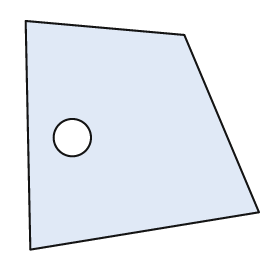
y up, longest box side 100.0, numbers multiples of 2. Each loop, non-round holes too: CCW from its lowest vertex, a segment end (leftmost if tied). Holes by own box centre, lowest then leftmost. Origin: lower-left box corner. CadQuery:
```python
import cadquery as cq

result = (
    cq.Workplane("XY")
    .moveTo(2.0, 0.0)
    .lineTo(100.0, 16.0)
    .lineTo(68.0, 92.0)
    .lineTo(0.0, 98.0)
    .close()
    .moveTo(20.0, 48.0)
    .circle(8.0)
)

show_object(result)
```